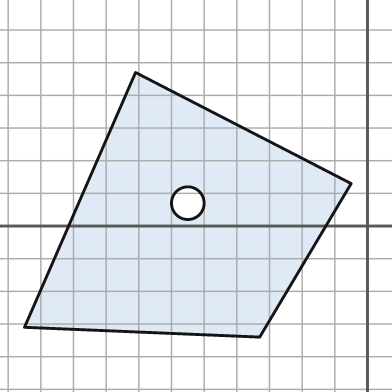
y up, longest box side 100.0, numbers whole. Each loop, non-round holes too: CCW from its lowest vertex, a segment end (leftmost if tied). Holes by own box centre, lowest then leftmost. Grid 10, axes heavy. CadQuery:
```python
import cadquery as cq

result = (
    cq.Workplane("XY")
    .moveTo(-33.0, -34.0)
    .lineTo(-5.0, 13.0)
    .lineTo(-71.0, 47.0)
    .lineTo(-105.0, -31.0)
    .close()
    .moveTo(-55.0, 7.0)
    .circle(5.0)
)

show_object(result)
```